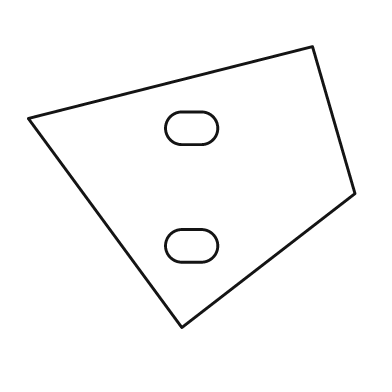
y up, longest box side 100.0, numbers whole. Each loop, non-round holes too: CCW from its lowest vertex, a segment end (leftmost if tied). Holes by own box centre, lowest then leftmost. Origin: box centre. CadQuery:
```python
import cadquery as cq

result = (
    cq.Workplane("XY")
    .moveTo(-3.0, -43.0)
    .lineTo(50.0, -2.0)
    .lineTo(37.0, 43.0)
    .lineTo(-50.0, 21.0)
    .close()
    .moveTo(-3.0, -23.0)
    .lineTo(3.0, -23.0)
    .threePointArc((8.0, -18.0), (3.0, -13.0))
    .lineTo(-3.0, -13.0)
    .threePointArc((-8.0, -18.0), (-3.0, -23.0))
    .close()
    .moveTo(-3.0, 13.0)
    .lineTo(3.0, 13.0)
    .threePointArc((8.0, 18.0), (3.0, 23.0))
    .lineTo(-3.0, 23.0)
    .threePointArc((-8.0, 18.0), (-3.0, 13.0))
    .close()
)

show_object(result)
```